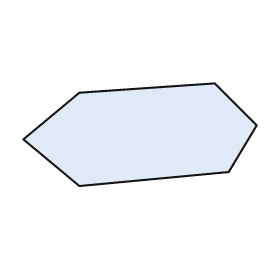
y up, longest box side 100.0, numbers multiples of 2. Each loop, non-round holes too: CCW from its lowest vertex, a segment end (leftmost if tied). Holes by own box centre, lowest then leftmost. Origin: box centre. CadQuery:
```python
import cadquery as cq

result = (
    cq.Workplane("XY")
    .moveTo(-26.0, -22.0)
    .lineTo(38.0, -16.0)
    .lineTo(50.0, 4.0)
    .lineTo(32.0, 22.0)
    .lineTo(-26.0, 18.0)
    .lineTo(-50.0, -2.0)
    .close()
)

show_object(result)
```